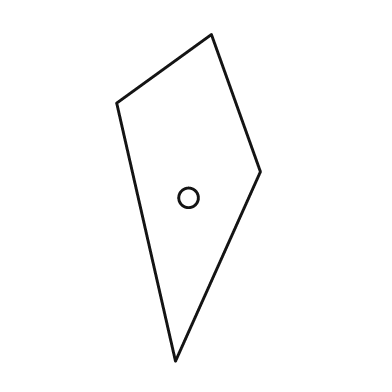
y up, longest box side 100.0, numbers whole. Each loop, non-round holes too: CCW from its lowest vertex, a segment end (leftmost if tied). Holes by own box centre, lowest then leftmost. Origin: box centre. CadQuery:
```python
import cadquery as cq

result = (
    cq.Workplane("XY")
    .moveTo(-4.0, -50.0)
    .lineTo(22.0, 8.0)
    .lineTo(7.0, 50.0)
    .lineTo(-22.0, 29.0)
    .close()
    .moveTo(0.0, 0.0)
    .circle(3.0)
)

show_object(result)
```